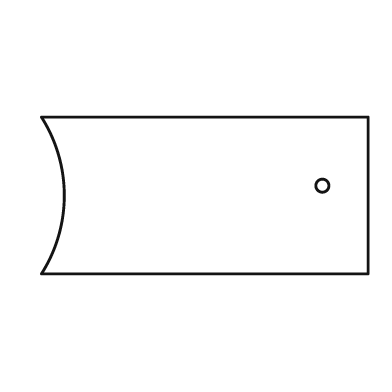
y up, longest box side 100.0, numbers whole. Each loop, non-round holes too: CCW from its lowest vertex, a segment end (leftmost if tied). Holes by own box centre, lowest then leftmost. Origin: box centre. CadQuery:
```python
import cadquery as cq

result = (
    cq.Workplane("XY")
    .moveTo(-50.0, -24.0)
    .lineTo(50.0, -24.0)
    .lineTo(50.0, 24.0)
    .lineTo(-50.0, 24.0)
    .threePointArc((-43.0, 0.0), (-50.0, -24.0))
    .close()
    .moveTo(36.0, 3.0)
    .circle(2.0)
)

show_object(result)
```